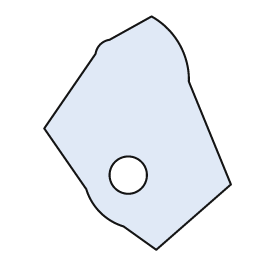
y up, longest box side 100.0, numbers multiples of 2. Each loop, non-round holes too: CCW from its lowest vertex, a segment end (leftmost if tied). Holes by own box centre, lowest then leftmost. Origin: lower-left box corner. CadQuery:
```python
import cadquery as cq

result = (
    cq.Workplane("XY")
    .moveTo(48.0, 0.0)
    .lineTo(80.0, 28.0)
    .lineTo(62.0, 72.0)
    .threePointArc((58.0, 88.0), (46.0, 100.0))
    .lineTo(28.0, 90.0)
    .threePointArc((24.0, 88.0), (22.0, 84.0))
    .lineTo(0.0, 52.0)
    .lineTo(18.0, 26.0)
    .threePointArc((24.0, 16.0), (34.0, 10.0))
    .close()
    .moveTo(36.0, 32.0)
    .circle(8.0)
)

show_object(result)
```